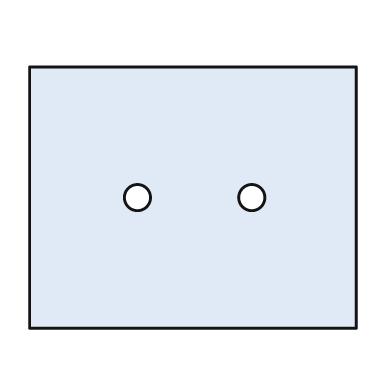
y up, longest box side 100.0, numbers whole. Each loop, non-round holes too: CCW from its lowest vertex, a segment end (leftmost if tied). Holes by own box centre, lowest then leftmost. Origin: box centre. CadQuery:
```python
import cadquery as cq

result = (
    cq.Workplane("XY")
    .moveTo(-50.0, -40.0)
    .lineTo(50.0, -40.0)
    .lineTo(50.0, 40.0)
    .lineTo(-50.0, 40.0)
    .close()
    .moveTo(-17.0, 0.0)
    .circle(4.0)
    .moveTo(18.0, 0.0)
    .circle(4.0)
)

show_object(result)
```